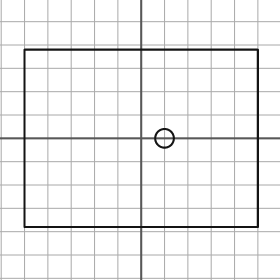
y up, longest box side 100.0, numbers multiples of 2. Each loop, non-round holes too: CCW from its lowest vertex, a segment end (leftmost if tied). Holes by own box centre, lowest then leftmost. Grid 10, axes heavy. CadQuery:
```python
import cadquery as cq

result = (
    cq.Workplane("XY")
    .moveTo(-50.0, -38.0)
    .lineTo(50.0, -38.0)
    .lineTo(50.0, 38.0)
    .lineTo(-50.0, 38.0)
    .close()
    .moveTo(10.0, 0.0)
    .circle(4.0)
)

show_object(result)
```